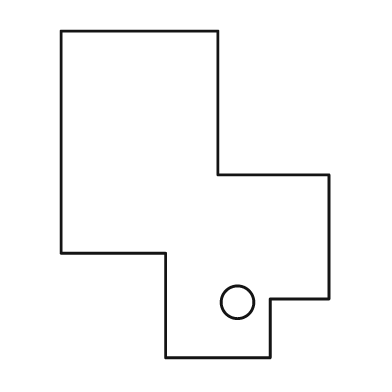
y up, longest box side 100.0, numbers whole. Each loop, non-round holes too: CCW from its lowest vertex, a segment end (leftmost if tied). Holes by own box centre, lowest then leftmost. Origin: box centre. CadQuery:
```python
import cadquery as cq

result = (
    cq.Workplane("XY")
    .moveTo(-9.0, -50.0)
    .lineTo(23.0, -50.0)
    .lineTo(23.0, -32.0)
    .lineTo(41.0, -32.0)
    .lineTo(41.0, 6.0)
    .lineTo(7.0, 6.0)
    .lineTo(7.0, 50.0)
    .lineTo(-41.0, 50.0)
    .lineTo(-41.0, -18.0)
    .lineTo(-9.0, -18.0)
    .close()
    .moveTo(13.0, -33.0)
    .circle(5.0)
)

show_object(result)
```